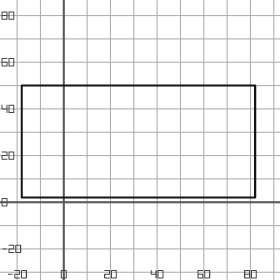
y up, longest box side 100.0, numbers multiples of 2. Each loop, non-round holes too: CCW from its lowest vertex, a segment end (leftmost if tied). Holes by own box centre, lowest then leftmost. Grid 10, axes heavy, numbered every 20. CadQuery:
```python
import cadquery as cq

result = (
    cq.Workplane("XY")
    .moveTo(-18.0, 2.0)
    .lineTo(82.0, 2.0)
    .lineTo(82.0, 50.0)
    .lineTo(-18.0, 50.0)
    .close()
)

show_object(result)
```